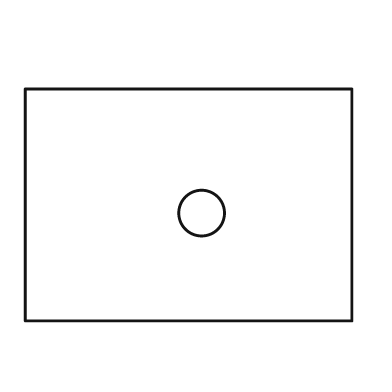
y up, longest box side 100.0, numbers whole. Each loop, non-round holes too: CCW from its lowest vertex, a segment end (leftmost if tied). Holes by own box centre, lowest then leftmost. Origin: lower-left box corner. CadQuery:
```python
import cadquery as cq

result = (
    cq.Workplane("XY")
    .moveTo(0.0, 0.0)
    .lineTo(100.0, 0.0)
    .lineTo(100.0, 71.0)
    .lineTo(0.0, 71.0)
    .close()
    .moveTo(54.0, 33.0)
    .circle(7.0)
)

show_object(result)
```